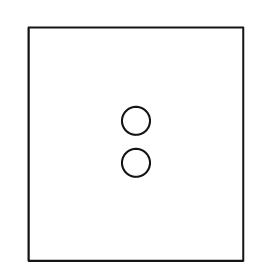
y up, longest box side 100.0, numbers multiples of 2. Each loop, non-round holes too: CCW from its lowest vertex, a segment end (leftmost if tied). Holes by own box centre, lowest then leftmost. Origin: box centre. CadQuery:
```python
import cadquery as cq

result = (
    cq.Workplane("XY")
    .moveTo(-46.0, -50.0)
    .lineTo(46.0, -50.0)
    .lineTo(46.0, 50.0)
    .lineTo(-46.0, 50.0)
    .close()
    .moveTo(0.0, -8.0)
    .circle(6.0)
    .moveTo(0.0, 10.0)
    .circle(6.0)
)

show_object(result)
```